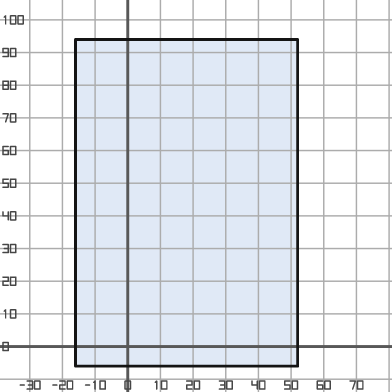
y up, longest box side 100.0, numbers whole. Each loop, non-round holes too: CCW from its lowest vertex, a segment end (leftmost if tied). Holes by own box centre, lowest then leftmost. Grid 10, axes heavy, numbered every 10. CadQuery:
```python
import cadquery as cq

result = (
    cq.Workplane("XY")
    .moveTo(-16.0, -6.0)
    .lineTo(52.0, -6.0)
    .lineTo(52.0, 94.0)
    .lineTo(-16.0, 94.0)
    .close()
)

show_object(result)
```